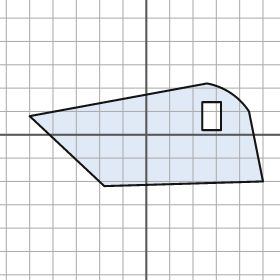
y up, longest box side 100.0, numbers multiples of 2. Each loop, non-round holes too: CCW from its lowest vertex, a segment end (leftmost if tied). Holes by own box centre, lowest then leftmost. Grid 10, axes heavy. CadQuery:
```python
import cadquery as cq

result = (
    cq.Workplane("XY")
    .moveTo(-18.0, -22.0)
    .lineTo(50.0, -20.0)
    .lineTo(44.0, 10.0)
    .threePointArc((36.0, 18.0), (26.0, 22.0))
    .lineTo(-50.0, 8.0)
    .close()
    .moveTo(24.0, 2.0)
    .lineTo(32.0, 2.0)
    .lineTo(32.0, 14.0)
    .lineTo(24.0, 14.0)
    .close()
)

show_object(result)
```